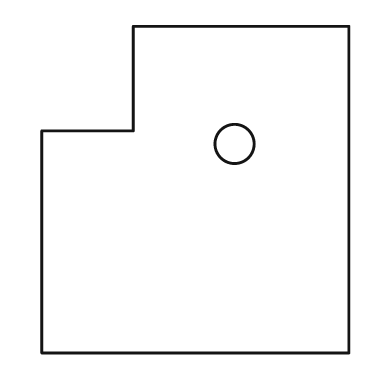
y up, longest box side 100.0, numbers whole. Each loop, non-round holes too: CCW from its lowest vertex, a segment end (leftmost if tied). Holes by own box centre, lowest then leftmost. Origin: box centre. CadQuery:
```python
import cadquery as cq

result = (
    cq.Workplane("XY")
    .moveTo(-47.0, -50.0)
    .lineTo(47.0, -50.0)
    .lineTo(47.0, 50.0)
    .lineTo(-19.0, 50.0)
    .lineTo(-19.0, 18.0)
    .lineTo(-47.0, 18.0)
    .close()
    .moveTo(12.0, 14.0)
    .circle(6.0)
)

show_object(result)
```